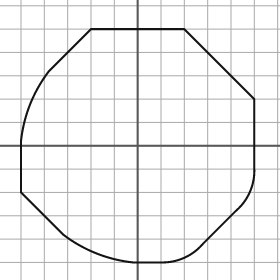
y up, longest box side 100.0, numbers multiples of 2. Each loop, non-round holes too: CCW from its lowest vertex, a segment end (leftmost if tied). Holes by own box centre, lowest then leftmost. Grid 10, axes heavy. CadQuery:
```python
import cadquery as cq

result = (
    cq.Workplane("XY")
    .moveTo(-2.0, -50.0)
    .lineTo(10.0, -50.0)
    .threePointArc((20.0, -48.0), (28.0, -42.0))
    .lineTo(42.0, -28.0)
    .threePointArc((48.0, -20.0), (50.0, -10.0))
    .lineTo(50.0, 20.0)
    .lineTo(20.0, 50.0)
    .lineTo(-20.0, 50.0)
    .lineTo(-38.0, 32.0)
    .threePointArc((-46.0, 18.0), (-50.0, 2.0))
    .lineTo(-50.0, -20.0)
    .lineTo(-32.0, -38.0)
    .threePointArc((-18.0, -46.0), (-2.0, -50.0))
    .close()
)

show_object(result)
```